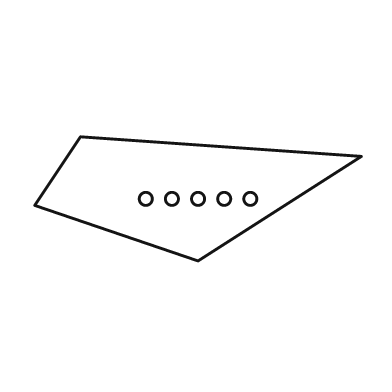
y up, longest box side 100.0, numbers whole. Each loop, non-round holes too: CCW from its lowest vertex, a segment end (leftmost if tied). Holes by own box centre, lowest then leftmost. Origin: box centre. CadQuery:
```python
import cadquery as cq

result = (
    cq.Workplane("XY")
    .moveTo(0.0, -19.0)
    .lineTo(50.0, 13.0)
    .lineTo(-36.0, 19.0)
    .lineTo(-50.0, -2.0)
    .close()
    .moveTo(-16.0, 0.0)
    .circle(2.0)
    .moveTo(-8.0, 0.0)
    .circle(2.0)
    .moveTo(0.0, 0.0)
    .circle(2.0)
    .moveTo(8.0, 0.0)
    .circle(2.0)
    .moveTo(16.0, 0.0)
    .circle(2.0)
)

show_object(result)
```